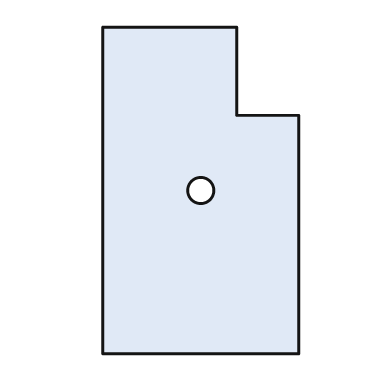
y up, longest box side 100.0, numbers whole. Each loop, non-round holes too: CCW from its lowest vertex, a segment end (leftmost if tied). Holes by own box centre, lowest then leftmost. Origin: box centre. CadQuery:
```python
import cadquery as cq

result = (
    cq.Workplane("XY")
    .moveTo(-30.0, -50.0)
    .lineTo(30.0, -50.0)
    .lineTo(30.0, 23.0)
    .lineTo(11.0, 23.0)
    .lineTo(11.0, 50.0)
    .lineTo(-30.0, 50.0)
    .close()
    .moveTo(0.0, 0.0)
    .circle(4.0)
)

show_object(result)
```